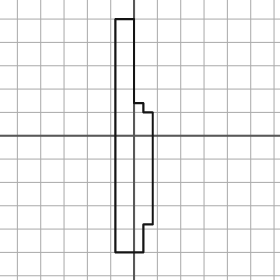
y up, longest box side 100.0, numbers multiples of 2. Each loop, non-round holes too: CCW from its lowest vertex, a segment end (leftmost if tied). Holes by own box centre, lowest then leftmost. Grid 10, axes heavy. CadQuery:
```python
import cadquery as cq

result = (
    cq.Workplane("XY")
    .moveTo(-8.0, -50.0)
    .lineTo(4.0, -50.0)
    .lineTo(4.0, -38.0)
    .lineTo(8.0, -38.0)
    .lineTo(8.0, 10.0)
    .lineTo(4.0, 10.0)
    .lineTo(4.0, 14.0)
    .lineTo(0.0, 14.0)
    .lineTo(0.0, 50.0)
    .lineTo(-8.0, 50.0)
    .close()
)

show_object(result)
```